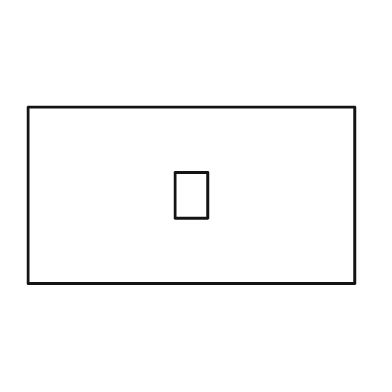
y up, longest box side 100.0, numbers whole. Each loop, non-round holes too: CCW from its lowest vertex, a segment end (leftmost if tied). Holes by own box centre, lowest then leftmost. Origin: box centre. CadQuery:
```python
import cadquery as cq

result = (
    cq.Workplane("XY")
    .moveTo(-50.0, -27.0)
    .lineTo(50.0, -27.0)
    .lineTo(50.0, 27.0)
    .lineTo(-50.0, 27.0)
    .close()
    .moveTo(-5.0, -7.0)
    .lineTo(5.0, -7.0)
    .lineTo(5.0, 7.0)
    .lineTo(-5.0, 7.0)
    .close()
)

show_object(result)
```